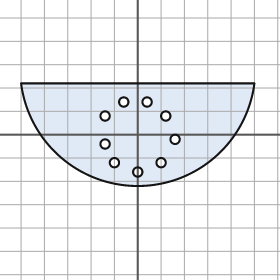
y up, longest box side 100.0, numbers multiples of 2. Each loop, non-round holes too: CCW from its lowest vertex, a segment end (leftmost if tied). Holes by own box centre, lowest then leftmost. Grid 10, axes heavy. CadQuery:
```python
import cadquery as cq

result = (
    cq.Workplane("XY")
    .moveTo(-50.0, 22.0)
    .threePointArc((0.0, -22.0), (50.0, 22.0))
    .close()
    .moveTo(0.0, -16.0)
    .circle(2.0)
    .moveTo(-10.0, -12.0)
    .circle(2.0)
    .moveTo(10.0, -12.0)
    .circle(2.0)
    .moveTo(-14.0, -4.0)
    .circle(2.0)
    .moveTo(16.0, -2.0)
    .circle(2.0)
    .moveTo(-14.0, 8.0)
    .circle(2.0)
    .moveTo(12.0, 8.0)
    .circle(2.0)
    .moveTo(-6.0, 14.0)
    .circle(2.0)
    .moveTo(4.0, 14.0)
    .circle(2.0)
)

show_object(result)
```